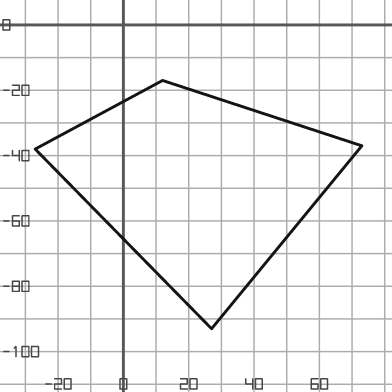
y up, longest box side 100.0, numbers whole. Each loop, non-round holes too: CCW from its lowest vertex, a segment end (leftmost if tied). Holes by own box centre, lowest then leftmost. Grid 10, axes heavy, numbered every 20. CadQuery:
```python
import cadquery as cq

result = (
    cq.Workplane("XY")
    .moveTo(27.0, -93.0)
    .lineTo(73.0, -37.0)
    .lineTo(12.0, -17.0)
    .lineTo(-27.0, -38.0)
    .close()
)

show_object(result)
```